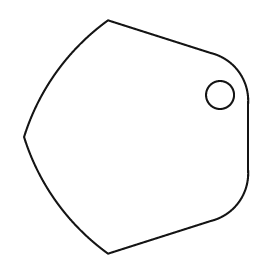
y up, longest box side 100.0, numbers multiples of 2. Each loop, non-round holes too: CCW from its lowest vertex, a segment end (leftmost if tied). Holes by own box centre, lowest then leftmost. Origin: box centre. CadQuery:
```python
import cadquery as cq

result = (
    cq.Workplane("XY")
    .moveTo(-12.0, -50.0)
    .lineTo(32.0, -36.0)
    .threePointArc((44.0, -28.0), (48.0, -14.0))
    .lineTo(48.0, 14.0)
    .threePointArc((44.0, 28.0), (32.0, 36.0))
    .lineTo(-12.0, 50.0)
    .threePointArc((-34.0, 28.0), (-48.0, 0.0))
    .threePointArc((-34.0, -28.0), (-12.0, -50.0))
    .close()
    .moveTo(36.0, 18.0)
    .circle(6.0)
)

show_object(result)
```